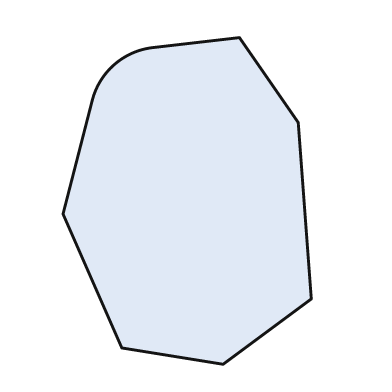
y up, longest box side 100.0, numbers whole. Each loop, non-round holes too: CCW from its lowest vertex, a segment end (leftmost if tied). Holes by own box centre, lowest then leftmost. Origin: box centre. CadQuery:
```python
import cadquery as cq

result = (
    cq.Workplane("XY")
    .moveTo(11.0, -50.0)
    .lineTo(38.0, -30.0)
    .lineTo(34.0, 24.0)
    .lineTo(16.0, 50.0)
    .lineTo(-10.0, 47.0)
    .threePointArc((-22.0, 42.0), (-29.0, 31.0))
    .lineTo(-38.0, -4.0)
    .lineTo(-20.0, -45.0)
    .close()
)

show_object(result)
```